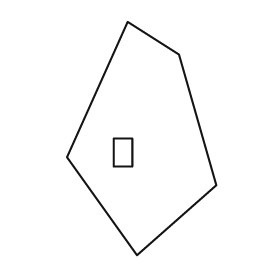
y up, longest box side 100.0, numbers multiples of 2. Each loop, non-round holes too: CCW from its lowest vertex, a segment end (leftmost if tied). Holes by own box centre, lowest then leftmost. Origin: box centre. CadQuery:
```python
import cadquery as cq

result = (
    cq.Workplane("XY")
    .moveTo(-2.0, -50.0)
    .lineTo(32.0, -20.0)
    .lineTo(16.0, 36.0)
    .lineTo(-6.0, 50.0)
    .lineTo(-32.0, -8.0)
    .close()
    .moveTo(-12.0, -12.0)
    .lineTo(-4.0, -12.0)
    .lineTo(-4.0, 0.0)
    .lineTo(-12.0, 0.0)
    .close()
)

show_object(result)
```